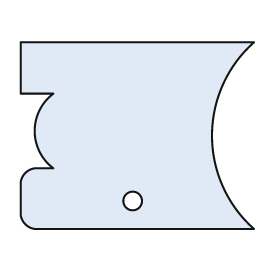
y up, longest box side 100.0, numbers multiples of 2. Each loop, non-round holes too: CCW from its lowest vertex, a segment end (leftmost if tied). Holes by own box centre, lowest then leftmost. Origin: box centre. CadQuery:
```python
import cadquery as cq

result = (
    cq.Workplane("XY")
    .moveTo(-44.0, -40.0)
    .lineTo(50.0, -40.0)
    .threePointArc((32.0, 0.0), (50.0, 40.0))
    .lineTo(-50.0, 40.0)
    .lineTo(-50.0, 18.0)
    .lineTo(-36.0, 18.0)
    .threePointArc((-44.0, 2.0), (-36.0, -14.0))
    .lineTo(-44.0, -14.0)
    .threePointArc((-48.0, -16.0), (-50.0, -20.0))
    .lineTo(-50.0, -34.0)
    .threePointArc((-48.0, -38.0), (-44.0, -40.0))
    .close()
    .moveTo(-2.0, -28.0)
    .circle(4.0)
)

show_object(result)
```